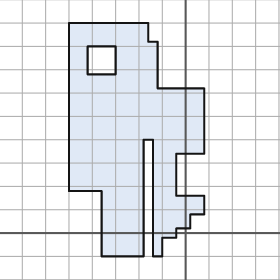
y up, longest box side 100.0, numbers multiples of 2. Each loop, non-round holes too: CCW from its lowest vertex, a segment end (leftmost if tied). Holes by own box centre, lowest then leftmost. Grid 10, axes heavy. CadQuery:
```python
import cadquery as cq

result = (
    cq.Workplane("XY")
    .moveTo(-36.0, -10.0)
    .lineTo(-18.0, -10.0)
    .lineTo(-18.0, 40.0)
    .lineTo(-14.0, 40.0)
    .lineTo(-14.0, -10.0)
    .lineTo(-10.0, -10.0)
    .lineTo(-10.0, -2.0)
    .lineTo(-4.0, -2.0)
    .lineTo(-4.0, 2.0)
    .lineTo(2.0, 2.0)
    .lineTo(2.0, 8.0)
    .lineTo(8.0, 8.0)
    .lineTo(8.0, 16.0)
    .lineTo(-4.0, 16.0)
    .lineTo(-4.0, 34.0)
    .lineTo(8.0, 34.0)
    .lineTo(8.0, 62.0)
    .lineTo(-12.0, 62.0)
    .lineTo(-12.0, 82.0)
    .lineTo(-16.0, 82.0)
    .lineTo(-16.0, 90.0)
    .lineTo(-50.0, 90.0)
    .lineTo(-50.0, 18.0)
    .lineTo(-36.0, 18.0)
    .close()
    .moveTo(-42.0, 68.0)
    .lineTo(-30.0, 68.0)
    .lineTo(-30.0, 80.0)
    .lineTo(-42.0, 80.0)
    .close()
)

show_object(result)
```